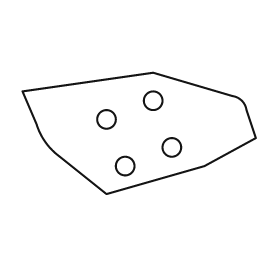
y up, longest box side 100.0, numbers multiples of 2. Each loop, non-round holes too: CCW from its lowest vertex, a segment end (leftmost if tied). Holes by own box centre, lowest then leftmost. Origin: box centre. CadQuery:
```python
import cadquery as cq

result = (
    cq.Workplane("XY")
    .moveTo(-14.0, -26.0)
    .lineTo(28.0, -14.0)
    .lineTo(50.0, -2.0)
    .lineTo(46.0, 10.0)
    .threePointArc((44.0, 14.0), (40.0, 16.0))
    .lineTo(6.0, 26.0)
    .lineTo(-50.0, 18.0)
    .lineTo(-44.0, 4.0)
    .threePointArc((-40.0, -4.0), (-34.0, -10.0))
    .close()
    .moveTo(-6.0, -14.0)
    .circle(4.0)
    .moveTo(14.0, -6.0)
    .circle(4.0)
    .moveTo(-14.0, 6.0)
    .circle(4.0)
    .moveTo(6.0, 14.0)
    .circle(4.0)
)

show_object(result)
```